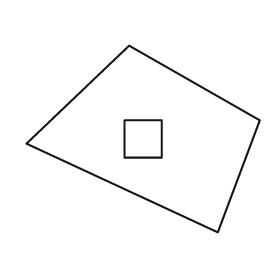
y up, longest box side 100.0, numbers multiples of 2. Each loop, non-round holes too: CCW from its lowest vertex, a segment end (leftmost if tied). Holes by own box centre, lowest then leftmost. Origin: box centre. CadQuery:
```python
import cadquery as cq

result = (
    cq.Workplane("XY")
    .moveTo(32.0, -40.0)
    .lineTo(50.0, 8.0)
    .lineTo(-6.0, 40.0)
    .lineTo(-50.0, -2.0)
    .close()
    .moveTo(-8.0, -8.0)
    .lineTo(8.0, -8.0)
    .lineTo(8.0, 8.0)
    .lineTo(-8.0, 8.0)
    .close()
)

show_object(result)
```